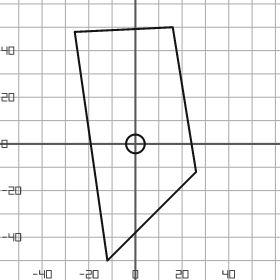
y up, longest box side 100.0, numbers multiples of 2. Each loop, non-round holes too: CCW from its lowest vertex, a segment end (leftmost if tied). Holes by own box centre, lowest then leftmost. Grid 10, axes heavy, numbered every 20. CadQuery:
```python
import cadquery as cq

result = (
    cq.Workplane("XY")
    .moveTo(-12.0, -50.0)
    .lineTo(26.0, -12.0)
    .lineTo(16.0, 50.0)
    .lineTo(-26.0, 48.0)
    .close()
    .moveTo(0.0, 0.0)
    .circle(4.0)
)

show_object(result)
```